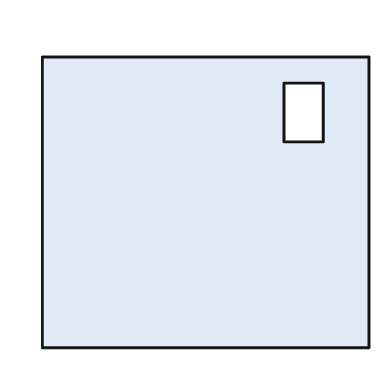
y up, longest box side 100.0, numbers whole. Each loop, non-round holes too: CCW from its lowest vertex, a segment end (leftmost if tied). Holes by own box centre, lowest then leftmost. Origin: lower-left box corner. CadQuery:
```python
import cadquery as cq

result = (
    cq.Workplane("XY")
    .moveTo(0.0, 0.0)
    .lineTo(100.0, 0.0)
    .lineTo(100.0, 89.0)
    .lineTo(0.0, 89.0)
    .close()
    .moveTo(74.0, 63.0)
    .lineTo(86.0, 63.0)
    .lineTo(86.0, 81.0)
    .lineTo(74.0, 81.0)
    .close()
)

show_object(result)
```